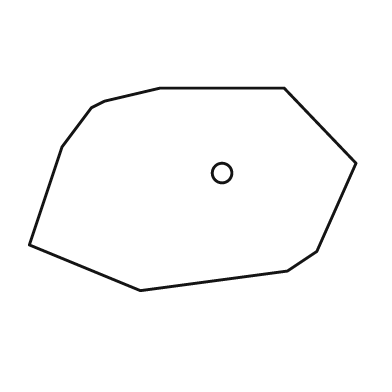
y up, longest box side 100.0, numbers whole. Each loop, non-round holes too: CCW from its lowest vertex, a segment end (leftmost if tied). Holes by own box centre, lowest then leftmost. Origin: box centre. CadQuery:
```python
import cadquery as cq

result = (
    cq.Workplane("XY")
    .moveTo(-16.0, -31.0)
    .lineTo(29.0, -25.0)
    .lineTo(38.0, -19.0)
    .lineTo(50.0, 8.0)
    .lineTo(28.0, 31.0)
    .lineTo(-10.0, 31.0)
    .lineTo(-27.0, 27.0)
    .lineTo(-31.0, 25.0)
    .lineTo(-40.0, 13.0)
    .lineTo(-50.0, -17.0)
    .close()
    .moveTo(9.0, 5.0)
    .circle(3.0)
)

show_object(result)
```